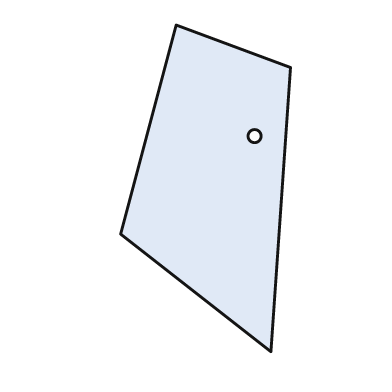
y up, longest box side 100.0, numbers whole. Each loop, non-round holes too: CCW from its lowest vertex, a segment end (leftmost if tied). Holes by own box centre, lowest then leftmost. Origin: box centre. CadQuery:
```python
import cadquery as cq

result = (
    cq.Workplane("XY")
    .moveTo(20.0, -50.0)
    .lineTo(26.0, 37.0)
    .lineTo(-9.0, 50.0)
    .lineTo(-26.0, -14.0)
    .close()
    .moveTo(15.0, 16.0)
    .circle(2.0)
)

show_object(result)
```